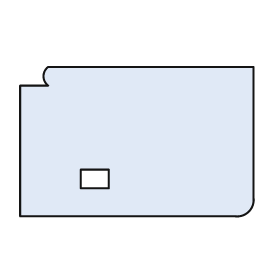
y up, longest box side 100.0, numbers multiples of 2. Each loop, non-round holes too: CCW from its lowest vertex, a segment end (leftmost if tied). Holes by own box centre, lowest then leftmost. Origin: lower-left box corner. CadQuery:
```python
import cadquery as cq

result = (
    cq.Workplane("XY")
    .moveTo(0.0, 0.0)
    .lineTo(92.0, 0.0)
    .threePointArc((98.0, 2.0), (100.0, 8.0))
    .lineTo(100.0, 64.0)
    .lineTo(12.0, 64.0)
    .threePointArc((10.0, 60.0), (12.0, 56.0))
    .lineTo(0.0, 56.0)
    .close()
    .moveTo(26.0, 12.0)
    .lineTo(38.0, 12.0)
    .lineTo(38.0, 20.0)
    .lineTo(26.0, 20.0)
    .close()
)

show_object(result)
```